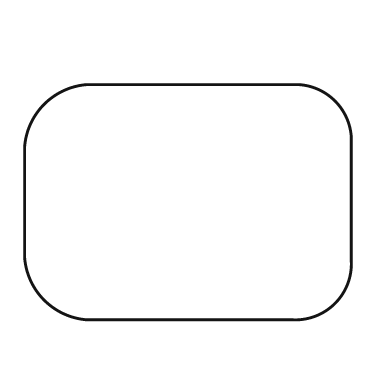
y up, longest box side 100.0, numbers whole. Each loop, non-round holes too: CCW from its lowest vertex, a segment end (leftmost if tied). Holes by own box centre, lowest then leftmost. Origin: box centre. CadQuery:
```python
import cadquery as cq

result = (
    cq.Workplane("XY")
    .moveTo(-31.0, -36.0)
    .lineTo(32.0, -36.0)
    .threePointArc((45.0, -31.0), (50.0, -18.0))
    .lineTo(50.0, 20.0)
    .threePointArc((45.0, 31.0), (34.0, 36.0))
    .lineTo(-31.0, 36.0)
    .threePointArc((-44.0, 30.0), (-50.0, 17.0))
    .lineTo(-50.0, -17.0)
    .threePointArc((-44.0, -30.0), (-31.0, -36.0))
    .close()
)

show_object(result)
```